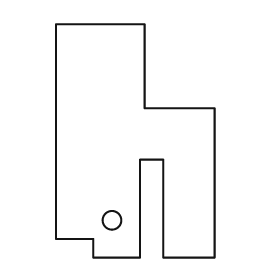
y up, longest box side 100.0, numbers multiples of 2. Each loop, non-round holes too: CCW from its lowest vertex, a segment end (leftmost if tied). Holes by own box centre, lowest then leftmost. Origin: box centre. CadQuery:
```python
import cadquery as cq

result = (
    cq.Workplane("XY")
    .moveTo(-18.0, -50.0)
    .lineTo(2.0, -50.0)
    .lineTo(2.0, -8.0)
    .lineTo(12.0, -8.0)
    .lineTo(12.0, -50.0)
    .lineTo(34.0, -50.0)
    .lineTo(34.0, 14.0)
    .lineTo(4.0, 14.0)
    .lineTo(4.0, 50.0)
    .lineTo(-34.0, 50.0)
    .lineTo(-34.0, -42.0)
    .lineTo(-18.0, -42.0)
    .close()
    .moveTo(-10.0, -34.0)
    .circle(4.0)
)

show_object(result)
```